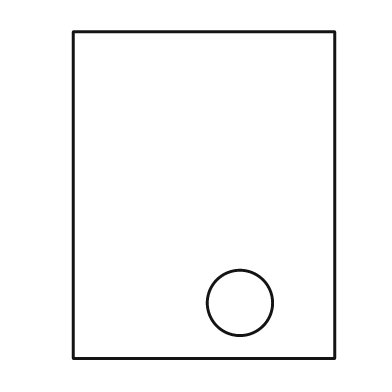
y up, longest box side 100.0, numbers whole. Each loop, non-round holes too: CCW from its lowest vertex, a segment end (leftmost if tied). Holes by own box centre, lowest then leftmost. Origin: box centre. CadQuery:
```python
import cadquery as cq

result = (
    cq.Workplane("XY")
    .moveTo(-40.0, -50.0)
    .lineTo(40.0, -50.0)
    .lineTo(40.0, 50.0)
    .lineTo(-40.0, 50.0)
    .close()
    .moveTo(11.0, -33.0)
    .circle(10.0)
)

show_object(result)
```